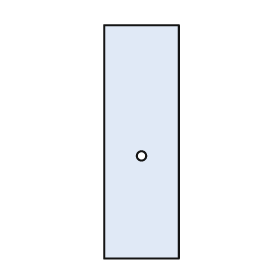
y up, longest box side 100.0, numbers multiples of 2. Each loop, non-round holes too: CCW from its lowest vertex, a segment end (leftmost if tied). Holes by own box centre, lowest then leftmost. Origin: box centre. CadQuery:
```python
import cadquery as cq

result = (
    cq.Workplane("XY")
    .moveTo(-16.0, -50.0)
    .lineTo(16.0, -50.0)
    .lineTo(16.0, 50.0)
    .lineTo(-16.0, 50.0)
    .close()
    .moveTo(0.0, -6.0)
    .circle(2.0)
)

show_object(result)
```